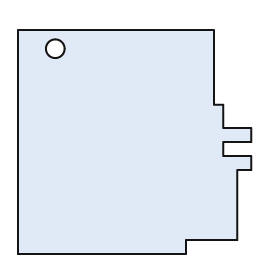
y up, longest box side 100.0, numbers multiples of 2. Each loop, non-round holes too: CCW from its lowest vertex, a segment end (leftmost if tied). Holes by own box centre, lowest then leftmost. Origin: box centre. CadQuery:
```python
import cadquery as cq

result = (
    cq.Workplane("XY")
    .moveTo(-50.0, -48.0)
    .lineTo(22.0, -48.0)
    .lineTo(22.0, -42.0)
    .lineTo(44.0, -42.0)
    .lineTo(44.0, -12.0)
    .lineTo(50.0, -12.0)
    .lineTo(50.0, -6.0)
    .lineTo(38.0, -6.0)
    .lineTo(38.0, 0.0)
    .lineTo(50.0, 0.0)
    .lineTo(50.0, 6.0)
    .lineTo(38.0, 6.0)
    .lineTo(38.0, 16.0)
    .lineTo(34.0, 16.0)
    .lineTo(34.0, 48.0)
    .lineTo(-50.0, 48.0)
    .close()
    .moveTo(-34.0, 40.0)
    .circle(4.0)
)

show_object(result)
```